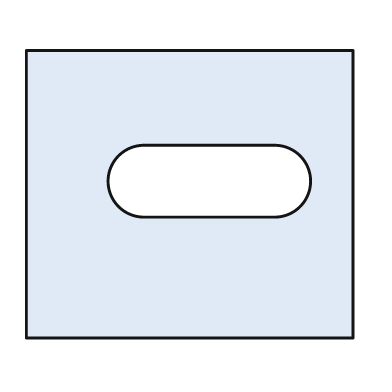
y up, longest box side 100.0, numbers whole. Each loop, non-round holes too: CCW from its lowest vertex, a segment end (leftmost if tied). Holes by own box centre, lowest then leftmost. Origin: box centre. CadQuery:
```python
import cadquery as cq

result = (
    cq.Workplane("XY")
    .moveTo(-50.0, -44.0)
    .lineTo(50.0, -44.0)
    .lineTo(50.0, 44.0)
    .lineTo(-50.0, 44.0)
    .close()
    .moveTo(-14.0, -7.0)
    .lineTo(26.0, -7.0)
    .threePointArc((37.0, 4.0), (26.0, 15.0))
    .lineTo(-14.0, 15.0)
    .threePointArc((-25.0, 4.0), (-14.0, -7.0))
    .close()
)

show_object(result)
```